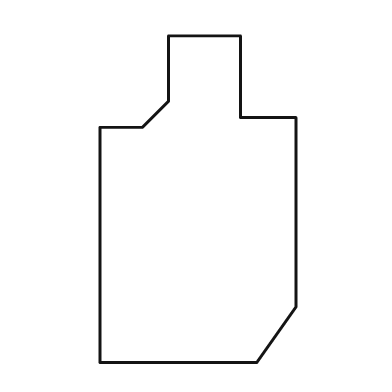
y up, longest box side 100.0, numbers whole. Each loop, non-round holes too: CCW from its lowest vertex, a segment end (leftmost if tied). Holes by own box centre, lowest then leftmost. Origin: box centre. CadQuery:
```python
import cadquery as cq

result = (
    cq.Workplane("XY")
    .moveTo(-30.0, -50.0)
    .lineTo(18.0, -50.0)
    .lineTo(30.0, -33.0)
    .lineTo(30.0, 25.0)
    .lineTo(13.0, 25.0)
    .lineTo(13.0, 50.0)
    .lineTo(-9.0, 50.0)
    .lineTo(-9.0, 30.0)
    .lineTo(-17.0, 22.0)
    .lineTo(-30.0, 22.0)
    .close()
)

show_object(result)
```